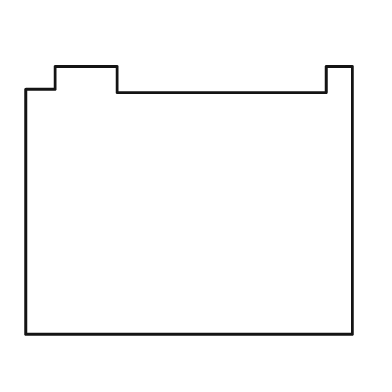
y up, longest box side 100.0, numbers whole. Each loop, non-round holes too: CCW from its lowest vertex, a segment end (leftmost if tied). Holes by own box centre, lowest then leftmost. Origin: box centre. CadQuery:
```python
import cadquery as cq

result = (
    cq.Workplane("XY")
    .moveTo(-50.0, -41.0)
    .lineTo(50.0, -41.0)
    .lineTo(50.0, 41.0)
    .lineTo(42.0, 41.0)
    .lineTo(42.0, 33.0)
    .lineTo(-22.0, 33.0)
    .lineTo(-22.0, 41.0)
    .lineTo(-41.0, 41.0)
    .lineTo(-41.0, 34.0)
    .lineTo(-50.0, 34.0)
    .close()
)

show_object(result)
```